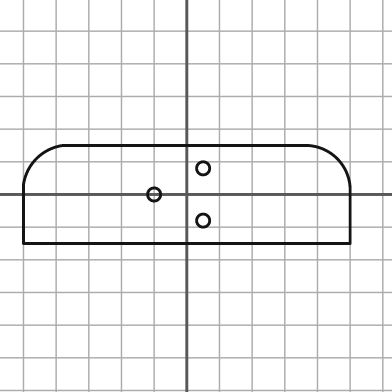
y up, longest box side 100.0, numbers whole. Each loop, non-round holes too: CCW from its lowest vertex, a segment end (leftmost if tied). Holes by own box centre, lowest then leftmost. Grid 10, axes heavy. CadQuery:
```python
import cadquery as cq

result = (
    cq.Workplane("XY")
    .moveTo(-50.0, -15.0)
    .lineTo(50.0, -15.0)
    .lineTo(50.0, 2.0)
    .threePointArc((46.0, 11.0), (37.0, 15.0))
    .lineTo(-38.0, 15.0)
    .threePointArc((-46.0, 11.0), (-50.0, 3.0))
    .close()
    .moveTo(5.0, -8.0)
    .circle(2.0)
    .moveTo(-10.0, 0.0)
    .circle(2.0)
    .moveTo(5.0, 8.0)
    .circle(2.0)
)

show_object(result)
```